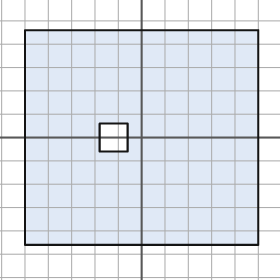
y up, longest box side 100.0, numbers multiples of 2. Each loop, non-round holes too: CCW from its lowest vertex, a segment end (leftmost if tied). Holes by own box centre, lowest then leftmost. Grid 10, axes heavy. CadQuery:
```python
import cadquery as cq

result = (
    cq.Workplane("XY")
    .moveTo(-50.0, -46.0)
    .lineTo(50.0, -46.0)
    .lineTo(50.0, 46.0)
    .lineTo(-50.0, 46.0)
    .close()
    .moveTo(-18.0, -6.0)
    .lineTo(-6.0, -6.0)
    .lineTo(-6.0, 6.0)
    .lineTo(-18.0, 6.0)
    .close()
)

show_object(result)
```